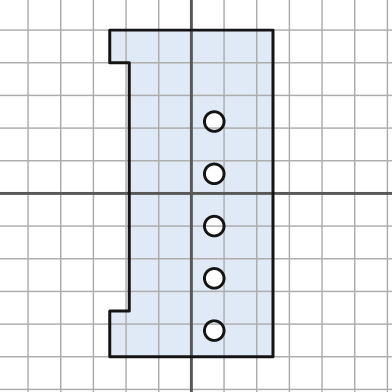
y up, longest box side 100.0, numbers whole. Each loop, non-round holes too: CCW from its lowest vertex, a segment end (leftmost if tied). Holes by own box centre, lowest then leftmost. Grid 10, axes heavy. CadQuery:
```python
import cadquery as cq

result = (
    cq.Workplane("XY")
    .moveTo(-25.0, -50.0)
    .lineTo(25.0, -50.0)
    .lineTo(25.0, 50.0)
    .lineTo(-25.0, 50.0)
    .lineTo(-25.0, 40.0)
    .lineTo(-19.0, 40.0)
    .lineTo(-19.0, -36.0)
    .lineTo(-25.0, -36.0)
    .close()
    .moveTo(7.0, -42.0)
    .circle(3.0)
    .moveTo(7.0, -26.0)
    .circle(3.0)
    .moveTo(7.0, -10.0)
    .circle(3.0)
    .moveTo(7.0, 6.0)
    .circle(3.0)
    .moveTo(7.0, 22.0)
    .circle(3.0)
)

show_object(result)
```